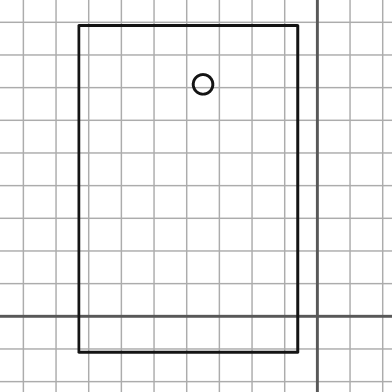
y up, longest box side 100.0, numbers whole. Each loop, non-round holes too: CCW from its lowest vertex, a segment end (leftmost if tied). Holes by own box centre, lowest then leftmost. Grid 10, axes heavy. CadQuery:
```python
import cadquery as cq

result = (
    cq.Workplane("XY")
    .moveTo(-73.0, -11.0)
    .lineTo(-6.0, -11.0)
    .lineTo(-6.0, 89.0)
    .lineTo(-73.0, 89.0)
    .close()
    .moveTo(-35.0, 71.0)
    .circle(3.0)
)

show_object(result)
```